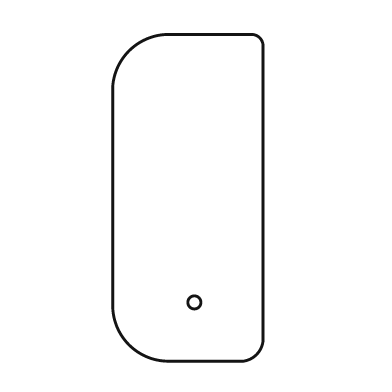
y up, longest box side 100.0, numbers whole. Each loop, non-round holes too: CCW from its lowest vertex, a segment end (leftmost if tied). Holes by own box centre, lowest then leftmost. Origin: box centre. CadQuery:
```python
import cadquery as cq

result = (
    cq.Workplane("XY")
    .moveTo(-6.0, -50.0)
    .lineTo(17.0, -50.0)
    .threePointArc((21.0, -48.0), (23.0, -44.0))
    .lineTo(23.0, 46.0)
    .threePointArc((22.0, 49.0), (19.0, 50.0))
    .lineTo(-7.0, 50.0)
    .threePointArc((-18.0, 45.0), (-23.0, 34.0))
    .lineTo(-23.0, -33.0)
    .threePointArc((-18.0, -45.0), (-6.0, -50.0))
    .close()
    .moveTo(2.0, -32.0)
    .circle(2.0)
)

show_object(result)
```